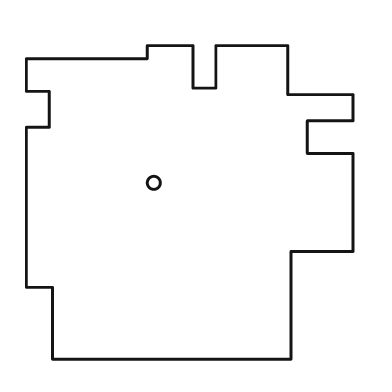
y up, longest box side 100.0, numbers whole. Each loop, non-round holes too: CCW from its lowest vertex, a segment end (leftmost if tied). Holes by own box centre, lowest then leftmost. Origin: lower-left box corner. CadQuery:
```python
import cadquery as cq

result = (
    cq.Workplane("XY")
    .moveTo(8.0, 0.0)
    .lineTo(81.0, 0.0)
    .lineTo(81.0, 33.0)
    .lineTo(100.0, 33.0)
    .lineTo(100.0, 63.0)
    .lineTo(86.0, 63.0)
    .lineTo(86.0, 73.0)
    .lineTo(100.0, 73.0)
    .lineTo(100.0, 81.0)
    .lineTo(80.0, 81.0)
    .lineTo(80.0, 96.0)
    .lineTo(58.0, 96.0)
    .lineTo(58.0, 83.0)
    .lineTo(51.0, 83.0)
    .lineTo(51.0, 96.0)
    .lineTo(37.0, 96.0)
    .lineTo(37.0, 92.0)
    .lineTo(0.0, 92.0)
    .lineTo(0.0, 82.0)
    .lineTo(7.0, 82.0)
    .lineTo(7.0, 71.0)
    .lineTo(0.0, 71.0)
    .lineTo(0.0, 22.0)
    .lineTo(8.0, 22.0)
    .close()
    .moveTo(39.0, 54.0)
    .circle(2.0)
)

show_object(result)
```